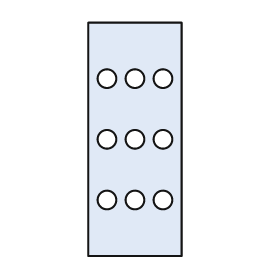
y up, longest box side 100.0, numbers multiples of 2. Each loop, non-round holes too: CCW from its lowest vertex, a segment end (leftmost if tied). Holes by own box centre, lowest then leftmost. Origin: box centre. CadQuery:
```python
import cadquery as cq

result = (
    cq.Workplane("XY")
    .moveTo(-20.0, -50.0)
    .lineTo(20.0, -50.0)
    .lineTo(20.0, 50.0)
    .lineTo(-20.0, 50.0)
    .close()
    .moveTo(-12.0, -26.0)
    .circle(4.0)
    .moveTo(0.0, -26.0)
    .circle(4.0)
    .moveTo(12.0, -26.0)
    .circle(4.0)
    .moveTo(-12.0, 0.0)
    .circle(4.0)
    .moveTo(0.0, 0.0)
    .circle(4.0)
    .moveTo(12.0, 0.0)
    .circle(4.0)
    .moveTo(-12.0, 26.0)
    .circle(4.0)
    .moveTo(0.0, 26.0)
    .circle(4.0)
    .moveTo(12.0, 26.0)
    .circle(4.0)
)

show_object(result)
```